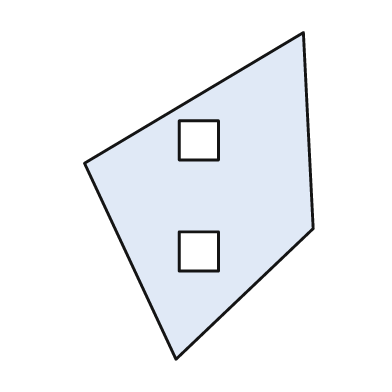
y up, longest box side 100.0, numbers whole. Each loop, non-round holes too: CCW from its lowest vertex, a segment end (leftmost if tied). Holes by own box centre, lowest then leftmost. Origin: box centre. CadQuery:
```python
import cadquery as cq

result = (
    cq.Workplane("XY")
    .moveTo(-7.0, -50.0)
    .lineTo(35.0, -10.0)
    .lineTo(32.0, 50.0)
    .lineTo(-35.0, 10.0)
    .close()
    .moveTo(-6.0, -23.0)
    .lineTo(6.0, -23.0)
    .lineTo(6.0, -11.0)
    .lineTo(-6.0, -11.0)
    .close()
    .moveTo(-6.0, 11.0)
    .lineTo(6.0, 11.0)
    .lineTo(6.0, 23.0)
    .lineTo(-6.0, 23.0)
    .close()
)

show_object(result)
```